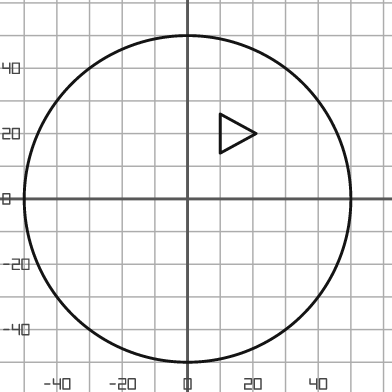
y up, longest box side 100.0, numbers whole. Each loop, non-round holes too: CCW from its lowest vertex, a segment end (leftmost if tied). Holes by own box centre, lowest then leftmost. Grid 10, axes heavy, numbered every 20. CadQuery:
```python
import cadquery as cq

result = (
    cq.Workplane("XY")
    .moveTo(0.0, 0.0)
    .circle(50.0)
    .moveTo(10.0, 14.0)
    .lineTo(21.0, 20.0)
    .lineTo(10.0, 26.0)
    .close()
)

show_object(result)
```